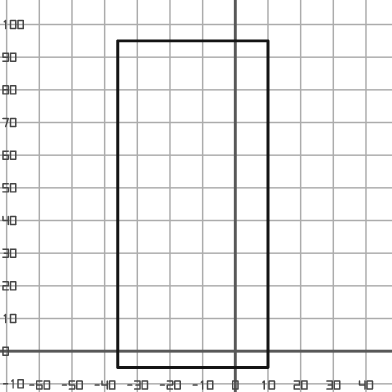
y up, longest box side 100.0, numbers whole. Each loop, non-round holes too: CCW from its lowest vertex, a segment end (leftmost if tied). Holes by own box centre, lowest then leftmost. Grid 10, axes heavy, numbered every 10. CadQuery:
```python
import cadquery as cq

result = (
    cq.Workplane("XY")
    .moveTo(-36.0, -5.0)
    .lineTo(10.0, -5.0)
    .lineTo(10.0, 95.0)
    .lineTo(-36.0, 95.0)
    .close()
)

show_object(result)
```